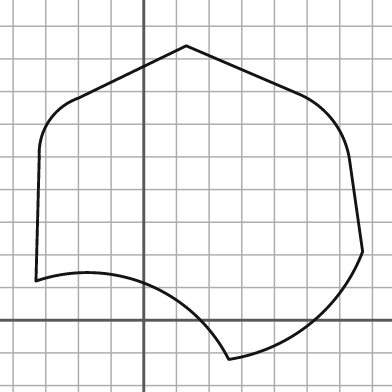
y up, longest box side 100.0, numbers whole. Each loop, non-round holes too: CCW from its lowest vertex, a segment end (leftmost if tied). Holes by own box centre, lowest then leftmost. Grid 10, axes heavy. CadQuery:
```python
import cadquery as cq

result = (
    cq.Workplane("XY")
    .moveTo(26.0, -12.0)
    .threePointArc((51.0, -1.0), (67.0, 21.0))
    .lineTo(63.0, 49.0)
    .threePointArc((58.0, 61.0), (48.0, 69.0))
    .lineTo(13.0, 84.0)
    .lineTo(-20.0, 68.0)
    .threePointArc((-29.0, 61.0), (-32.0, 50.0))
    .lineTo(-33.0, 12.0)
    .threePointArc((1.0, 11.0), (26.0, -12.0))
    .close()
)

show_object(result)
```